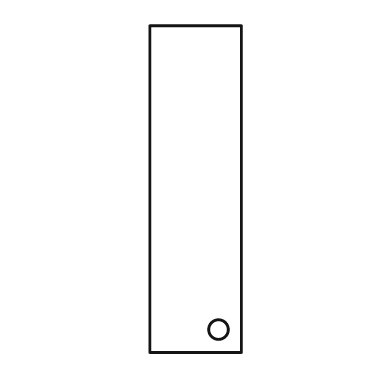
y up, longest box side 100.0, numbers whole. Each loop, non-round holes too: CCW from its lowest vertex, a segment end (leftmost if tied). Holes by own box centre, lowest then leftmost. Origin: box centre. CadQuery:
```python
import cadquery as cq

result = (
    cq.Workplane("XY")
    .moveTo(-14.0, -50.0)
    .lineTo(14.0, -50.0)
    .lineTo(14.0, 50.0)
    .lineTo(-14.0, 50.0)
    .close()
    .moveTo(7.0, -43.0)
    .circle(3.0)
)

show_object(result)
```